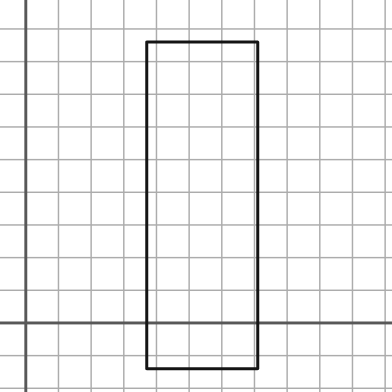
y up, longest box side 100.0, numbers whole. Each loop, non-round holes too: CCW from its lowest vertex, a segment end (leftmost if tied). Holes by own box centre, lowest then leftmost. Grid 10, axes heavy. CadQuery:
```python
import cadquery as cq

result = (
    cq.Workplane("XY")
    .moveTo(37.0, -14.0)
    .lineTo(71.0, -14.0)
    .lineTo(71.0, 86.0)
    .lineTo(37.0, 86.0)
    .close()
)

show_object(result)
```